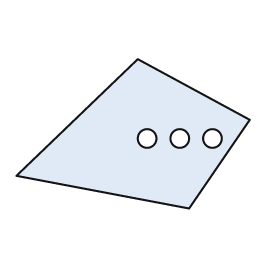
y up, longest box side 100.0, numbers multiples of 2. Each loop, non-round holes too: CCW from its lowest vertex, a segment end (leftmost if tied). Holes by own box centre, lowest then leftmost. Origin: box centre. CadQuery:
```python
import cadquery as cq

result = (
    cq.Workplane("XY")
    .moveTo(24.0, -32.0)
    .lineTo(50.0, 6.0)
    .lineTo(2.0, 32.0)
    .lineTo(-50.0, -18.0)
    .close()
    .moveTo(6.0, -2.0)
    .circle(4.0)
    .moveTo(20.0, -2.0)
    .circle(4.0)
    .moveTo(34.0, -2.0)
    .circle(4.0)
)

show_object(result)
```